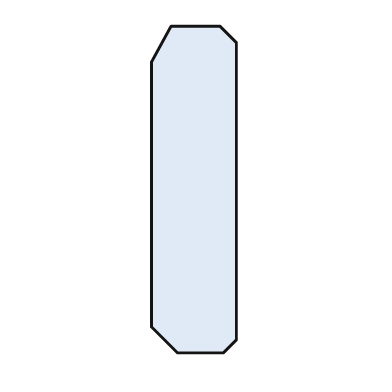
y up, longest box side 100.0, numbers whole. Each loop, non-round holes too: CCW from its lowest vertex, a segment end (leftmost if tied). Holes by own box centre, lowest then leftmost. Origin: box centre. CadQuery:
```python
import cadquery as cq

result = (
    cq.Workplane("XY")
    .moveTo(-5.0, -50.0)
    .lineTo(9.0, -50.0)
    .lineTo(13.0, -46.0)
    .lineTo(13.0, 45.0)
    .lineTo(8.0, 50.0)
    .lineTo(-7.0, 50.0)
    .lineTo(-13.0, 39.0)
    .lineTo(-13.0, -42.0)
    .close()
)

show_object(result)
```